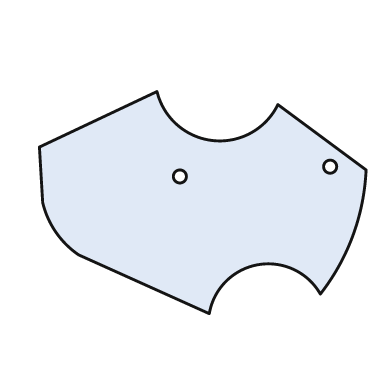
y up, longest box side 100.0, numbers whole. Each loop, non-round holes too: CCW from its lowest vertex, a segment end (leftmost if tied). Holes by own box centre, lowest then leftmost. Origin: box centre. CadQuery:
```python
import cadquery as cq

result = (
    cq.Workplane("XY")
    .moveTo(2.0, -34.0)
    .threePointArc((17.0, -19.0), (36.0, -28.0))
    .threePointArc((46.0, -10.0), (50.0, 10.0))
    .lineTo(23.0, 30.0)
    .threePointArc((3.0, 19.0), (-14.0, 34.0))
    .lineTo(-50.0, 17.0)
    .lineTo(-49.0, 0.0)
    .threePointArc((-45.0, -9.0), (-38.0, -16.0))
    .close()
    .moveTo(-7.0, 8.0)
    .circle(2.0)
    .moveTo(39.0, 11.0)
    .circle(2.0)
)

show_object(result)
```